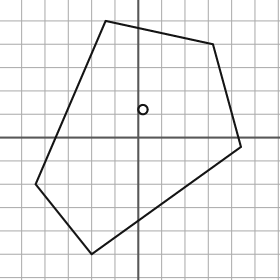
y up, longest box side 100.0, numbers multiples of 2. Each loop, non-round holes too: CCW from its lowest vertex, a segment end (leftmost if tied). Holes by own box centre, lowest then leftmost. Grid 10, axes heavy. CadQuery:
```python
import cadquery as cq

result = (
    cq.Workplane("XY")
    .moveTo(-20.0, -50.0)
    .lineTo(44.0, -4.0)
    .lineTo(32.0, 40.0)
    .lineTo(-14.0, 50.0)
    .lineTo(-44.0, -20.0)
    .close()
    .moveTo(2.0, 12.0)
    .circle(2.0)
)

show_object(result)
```